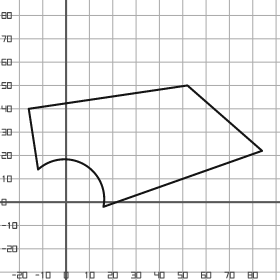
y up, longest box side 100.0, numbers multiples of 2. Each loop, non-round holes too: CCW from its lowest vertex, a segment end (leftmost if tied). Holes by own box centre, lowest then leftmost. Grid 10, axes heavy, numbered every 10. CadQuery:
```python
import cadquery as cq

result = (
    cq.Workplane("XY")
    .moveTo(16.0, -2.0)
    .lineTo(84.0, 22.0)
    .lineTo(52.0, 50.0)
    .lineTo(-16.0, 40.0)
    .lineTo(-12.0, 14.0)
    .threePointArc((8.0, 16.0), (16.0, -2.0))
    .close()
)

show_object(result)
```